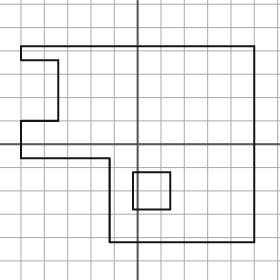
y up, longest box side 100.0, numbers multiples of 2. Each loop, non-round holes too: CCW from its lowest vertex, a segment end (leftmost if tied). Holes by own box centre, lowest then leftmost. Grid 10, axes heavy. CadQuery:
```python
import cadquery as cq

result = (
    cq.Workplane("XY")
    .moveTo(-12.0, -42.0)
    .lineTo(50.0, -42.0)
    .lineTo(50.0, 42.0)
    .lineTo(-50.0, 42.0)
    .lineTo(-50.0, 36.0)
    .lineTo(-34.0, 36.0)
    .lineTo(-34.0, 10.0)
    .lineTo(-50.0, 10.0)
    .lineTo(-50.0, -6.0)
    .lineTo(-12.0, -6.0)
    .close()
    .moveTo(-2.0, -28.0)
    .lineTo(14.0, -28.0)
    .lineTo(14.0, -12.0)
    .lineTo(-2.0, -12.0)
    .close()
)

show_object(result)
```